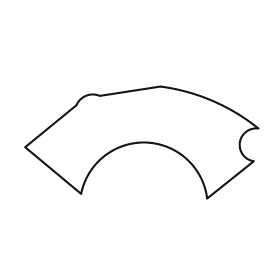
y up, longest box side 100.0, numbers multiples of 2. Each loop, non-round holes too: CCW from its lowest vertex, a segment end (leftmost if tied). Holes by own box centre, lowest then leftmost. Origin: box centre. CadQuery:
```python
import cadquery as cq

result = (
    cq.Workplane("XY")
    .moveTo(28.0, -24.0)
    .lineTo(48.0, -8.0)
    .threePointArc((42.0, 0.0), (50.0, 6.0))
    .threePointArc((30.0, 18.0), (8.0, 24.0))
    .lineTo(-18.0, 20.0)
    .threePointArc((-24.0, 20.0), (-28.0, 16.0))
    .lineTo(-50.0, -2.0)
    .lineTo(-26.0, -22.0)
    .threePointArc((2.0, 0.0), (28.0, -24.0))
    .close()
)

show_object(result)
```